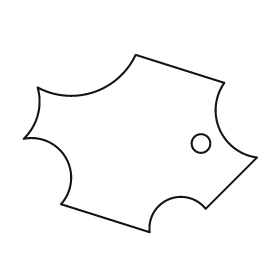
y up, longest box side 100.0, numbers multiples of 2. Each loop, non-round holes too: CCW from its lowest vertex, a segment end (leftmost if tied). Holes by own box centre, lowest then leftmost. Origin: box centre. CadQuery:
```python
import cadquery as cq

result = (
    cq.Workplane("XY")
    .moveTo(4.0, -38.0)
    .threePointArc((12.0, -24.0), (28.0, -28.0))
    .lineTo(50.0, -6.0)
    .threePointArc((34.0, 6.0), (36.0, 26.0))
    .lineTo(-2.0, 38.0)
    .threePointArc((-20.0, 22.0), (-44.0, 24.0))
    .threePointArc((-44.0, 12.0), (-50.0, 2.0))
    .threePointArc((-32.0, -6.0), (-34.0, -26.0))
    .close()
    .moveTo(26.0, 0.0)
    .circle(4.0)
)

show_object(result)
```